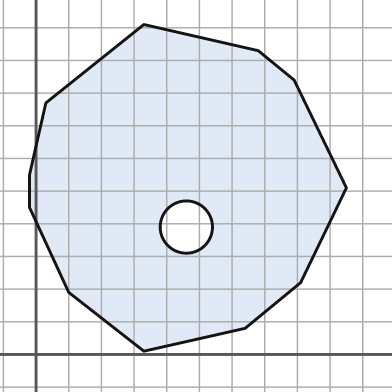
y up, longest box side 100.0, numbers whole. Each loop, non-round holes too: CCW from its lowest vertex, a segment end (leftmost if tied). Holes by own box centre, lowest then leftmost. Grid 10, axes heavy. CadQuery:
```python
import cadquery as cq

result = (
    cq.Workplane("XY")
    .moveTo(33.0, 1.0)
    .lineTo(64.0, 8.0)
    .lineTo(81.0, 22.0)
    .lineTo(95.0, 51.0)
    .lineTo(79.0, 84.0)
    .lineTo(68.0, 93.0)
    .lineTo(33.0, 101.0)
    .lineTo(3.0, 77.0)
    .lineTo(-2.0, 55.0)
    .lineTo(-2.0, 45.0)
    .lineTo(10.0, 19.0)
    .close()
    .moveTo(46.0, 39.0)
    .circle(8.0)
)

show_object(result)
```